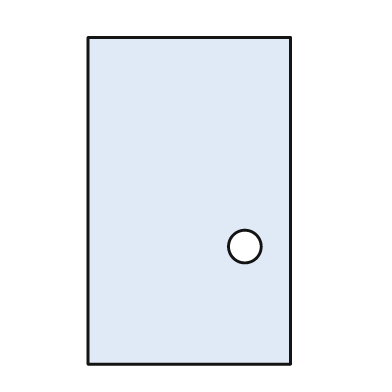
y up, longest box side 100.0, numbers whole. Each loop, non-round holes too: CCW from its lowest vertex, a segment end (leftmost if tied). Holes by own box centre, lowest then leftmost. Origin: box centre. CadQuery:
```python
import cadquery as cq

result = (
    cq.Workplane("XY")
    .moveTo(-31.0, -50.0)
    .lineTo(31.0, -50.0)
    .lineTo(31.0, 50.0)
    .lineTo(-31.0, 50.0)
    .close()
    .moveTo(17.0, -14.0)
    .circle(5.0)
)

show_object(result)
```